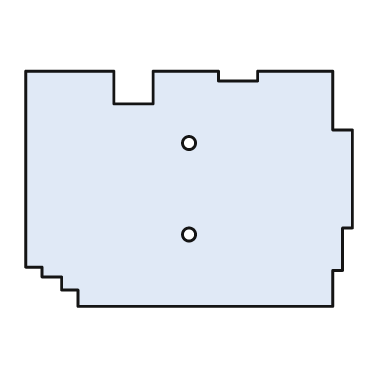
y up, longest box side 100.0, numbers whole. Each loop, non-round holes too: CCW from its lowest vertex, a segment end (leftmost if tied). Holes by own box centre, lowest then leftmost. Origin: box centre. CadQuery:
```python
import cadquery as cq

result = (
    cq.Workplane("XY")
    .moveTo(-34.0, -36.0)
    .lineTo(44.0, -36.0)
    .lineTo(44.0, -25.0)
    .lineTo(47.0, -25.0)
    .lineTo(47.0, -12.0)
    .lineTo(50.0, -12.0)
    .lineTo(50.0, 18.0)
    .lineTo(44.0, 18.0)
    .lineTo(44.0, 36.0)
    .lineTo(21.0, 36.0)
    .lineTo(21.0, 33.0)
    .lineTo(9.0, 33.0)
    .lineTo(9.0, 36.0)
    .lineTo(-11.0, 36.0)
    .lineTo(-11.0, 26.0)
    .lineTo(-23.0, 26.0)
    .lineTo(-23.0, 36.0)
    .lineTo(-50.0, 36.0)
    .lineTo(-50.0, -24.0)
    .lineTo(-45.0, -24.0)
    .lineTo(-45.0, -27.0)
    .lineTo(-39.0, -27.0)
    .lineTo(-39.0, -31.0)
    .lineTo(-34.0, -31.0)
    .close()
    .moveTo(0.0, -14.0)
    .circle(2.0)
    .moveTo(0.0, 14.0)
    .circle(2.0)
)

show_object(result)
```